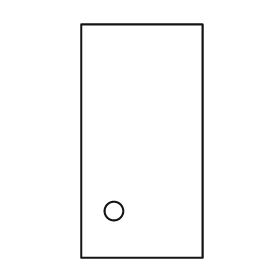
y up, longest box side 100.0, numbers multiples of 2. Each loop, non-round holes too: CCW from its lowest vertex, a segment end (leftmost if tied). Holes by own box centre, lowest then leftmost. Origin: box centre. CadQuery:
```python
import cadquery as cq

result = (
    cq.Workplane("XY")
    .moveTo(-26.0, -50.0)
    .lineTo(26.0, -50.0)
    .lineTo(26.0, 50.0)
    .lineTo(-26.0, 50.0)
    .close()
    .moveTo(-12.0, -30.0)
    .circle(4.0)
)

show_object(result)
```